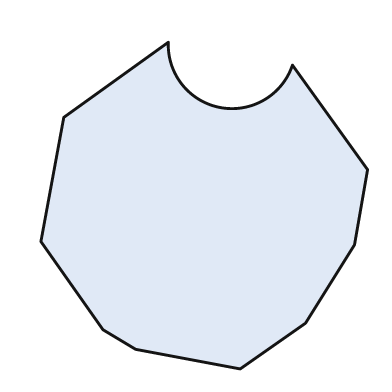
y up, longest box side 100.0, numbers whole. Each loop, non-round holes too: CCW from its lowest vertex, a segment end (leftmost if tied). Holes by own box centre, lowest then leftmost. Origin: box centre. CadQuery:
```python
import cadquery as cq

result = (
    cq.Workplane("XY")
    .moveTo(11.0, -50.0)
    .lineTo(31.0, -36.0)
    .lineTo(46.0, -12.0)
    .lineTo(50.0, 11.0)
    .lineTo(27.0, 43.0)
    .threePointArc((5.0, 30.0), (-11.0, 50.0))
    .lineTo(-43.0, 27.0)
    .lineTo(-50.0, -11.0)
    .lineTo(-31.0, -38.0)
    .lineTo(-21.0, -44.0)
    .close()
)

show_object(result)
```